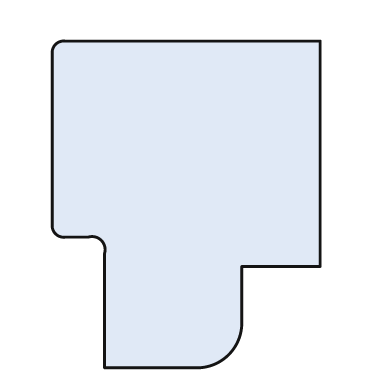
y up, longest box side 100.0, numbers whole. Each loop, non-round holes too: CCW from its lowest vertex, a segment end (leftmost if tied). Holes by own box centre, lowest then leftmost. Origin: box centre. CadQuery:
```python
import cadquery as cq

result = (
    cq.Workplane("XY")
    .moveTo(-25.0, -50.0)
    .lineTo(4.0, -50.0)
    .threePointArc((13.0, -46.0), (17.0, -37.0))
    .lineTo(17.0, -19.0)
    .lineTo(41.0, -19.0)
    .lineTo(41.0, 50.0)
    .lineTo(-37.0, 50.0)
    .threePointArc((-40.0, 49.0), (-41.0, 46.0))
    .lineTo(-41.0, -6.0)
    .threePointArc((-40.0, -9.0), (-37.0, -10.0))
    .lineTo(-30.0, -10.0)
    .threePointArc((-26.0, -11.0), (-25.0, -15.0))
    .close()
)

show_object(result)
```